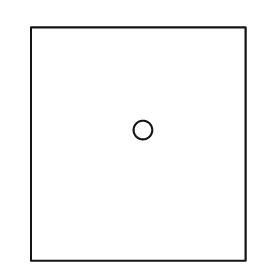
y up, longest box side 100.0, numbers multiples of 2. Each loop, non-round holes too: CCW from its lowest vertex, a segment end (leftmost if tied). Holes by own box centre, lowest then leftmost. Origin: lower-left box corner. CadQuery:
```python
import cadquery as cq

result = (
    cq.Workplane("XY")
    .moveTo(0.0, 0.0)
    .lineTo(92.0, 0.0)
    .lineTo(92.0, 100.0)
    .lineTo(0.0, 100.0)
    .close()
    .moveTo(48.0, 56.0)
    .circle(4.0)
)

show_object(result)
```